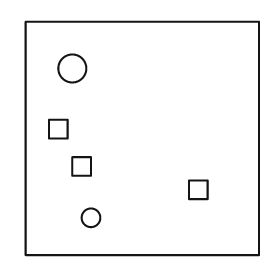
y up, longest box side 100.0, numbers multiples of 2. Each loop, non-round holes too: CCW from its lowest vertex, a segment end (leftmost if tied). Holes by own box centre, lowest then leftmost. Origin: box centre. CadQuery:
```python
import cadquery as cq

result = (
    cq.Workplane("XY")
    .moveTo(-50.0, -50.0)
    .lineTo(50.0, -50.0)
    .lineTo(50.0, 50.0)
    .lineTo(-50.0, 50.0)
    .close()
    .moveTo(-22.0, -34.0)
    .circle(4.0)
    .moveTo(20.0, -26.0)
    .lineTo(28.0, -26.0)
    .lineTo(28.0, -18.0)
    .lineTo(20.0, -18.0)
    .close()
    .moveTo(-30.0, -16.0)
    .lineTo(-22.0, -16.0)
    .lineTo(-22.0, -8.0)
    .lineTo(-30.0, -8.0)
    .close()
    .moveTo(-40.0, 0.0)
    .lineTo(-32.0, 0.0)
    .lineTo(-32.0, 8.0)
    .lineTo(-40.0, 8.0)
    .close()
    .moveTo(-30.0, 30.0)
    .circle(6.0)
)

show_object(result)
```